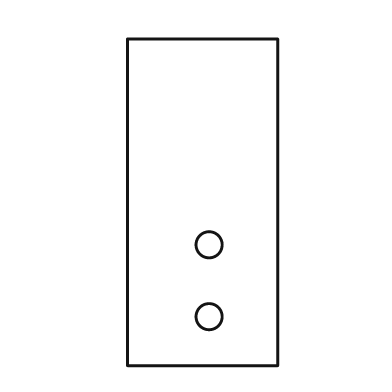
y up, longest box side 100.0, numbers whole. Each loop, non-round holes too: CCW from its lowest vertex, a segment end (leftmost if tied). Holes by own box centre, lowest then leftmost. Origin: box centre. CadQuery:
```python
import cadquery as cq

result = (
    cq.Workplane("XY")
    .moveTo(-23.0, -50.0)
    .lineTo(23.0, -50.0)
    .lineTo(23.0, 50.0)
    .lineTo(-23.0, 50.0)
    .close()
    .moveTo(2.0, -35.0)
    .circle(4.0)
    .moveTo(2.0, -13.0)
    .circle(4.0)
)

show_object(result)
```